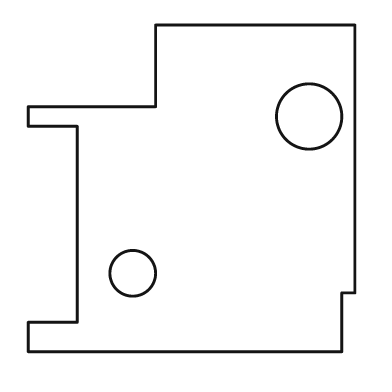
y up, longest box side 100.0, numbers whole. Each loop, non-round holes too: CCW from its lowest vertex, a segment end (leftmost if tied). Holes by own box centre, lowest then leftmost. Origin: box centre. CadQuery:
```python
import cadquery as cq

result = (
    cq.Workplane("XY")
    .moveTo(-50.0, -50.0)
    .lineTo(46.0, -50.0)
    .lineTo(46.0, -32.0)
    .lineTo(50.0, -32.0)
    .lineTo(50.0, 50.0)
    .lineTo(-11.0, 50.0)
    .lineTo(-11.0, 25.0)
    .lineTo(-50.0, 25.0)
    .lineTo(-50.0, 19.0)
    .lineTo(-35.0, 19.0)
    .lineTo(-35.0, -41.0)
    .lineTo(-50.0, -41.0)
    .close()
    .moveTo(-18.0, -26.0)
    .circle(7.0)
    .moveTo(36.0, 22.0)
    .circle(10.0)
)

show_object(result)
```